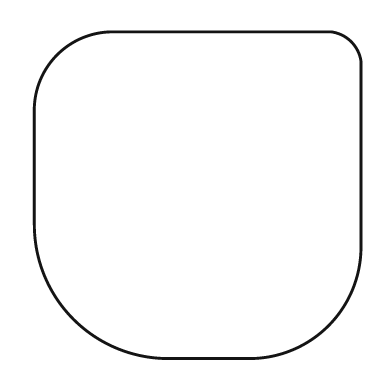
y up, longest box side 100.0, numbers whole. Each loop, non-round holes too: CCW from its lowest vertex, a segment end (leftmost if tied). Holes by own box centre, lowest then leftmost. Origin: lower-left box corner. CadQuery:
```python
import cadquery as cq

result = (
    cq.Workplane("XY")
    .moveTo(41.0, 0.0)
    .lineTo(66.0, 0.0)
    .threePointArc((90.0, 10.0), (100.0, 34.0))
    .lineTo(100.0, 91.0)
    .threePointArc((97.0, 97.0), (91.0, 100.0))
    .lineTo(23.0, 100.0)
    .threePointArc((7.0, 93.0), (0.0, 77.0))
    .lineTo(0.0, 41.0)
    .threePointArc((12.0, 12.0), (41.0, 0.0))
    .close()
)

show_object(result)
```